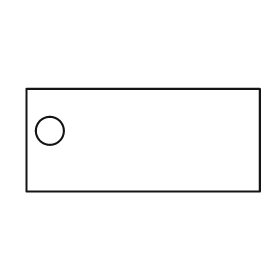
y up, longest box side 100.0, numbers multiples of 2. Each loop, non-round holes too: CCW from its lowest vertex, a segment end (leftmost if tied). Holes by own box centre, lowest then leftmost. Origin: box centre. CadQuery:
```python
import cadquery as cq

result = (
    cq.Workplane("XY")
    .moveTo(-50.0, -22.0)
    .lineTo(50.0, -22.0)
    .lineTo(50.0, 22.0)
    .lineTo(-50.0, 22.0)
    .close()
    .moveTo(-40.0, 4.0)
    .circle(6.0)
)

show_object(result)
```